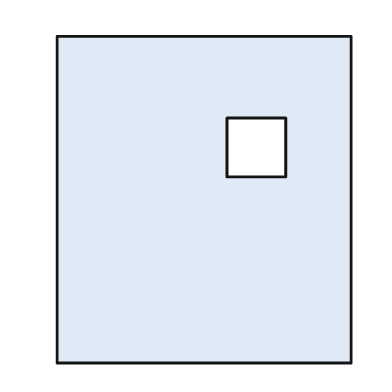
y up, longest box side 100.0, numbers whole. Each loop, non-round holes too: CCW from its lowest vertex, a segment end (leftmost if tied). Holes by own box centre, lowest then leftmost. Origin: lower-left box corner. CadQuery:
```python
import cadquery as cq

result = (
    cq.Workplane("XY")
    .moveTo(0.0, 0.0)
    .lineTo(90.0, 0.0)
    .lineTo(90.0, 100.0)
    .lineTo(0.0, 100.0)
    .close()
    .moveTo(52.0, 57.0)
    .lineTo(70.0, 57.0)
    .lineTo(70.0, 75.0)
    .lineTo(52.0, 75.0)
    .close()
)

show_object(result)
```